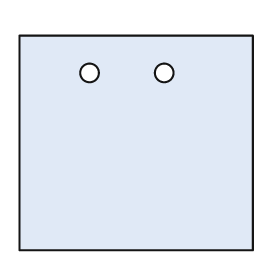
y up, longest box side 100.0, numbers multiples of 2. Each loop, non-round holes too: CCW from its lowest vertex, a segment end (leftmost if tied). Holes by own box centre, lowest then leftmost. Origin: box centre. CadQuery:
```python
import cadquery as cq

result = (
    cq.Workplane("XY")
    .moveTo(-50.0, -46.0)
    .lineTo(50.0, -46.0)
    .lineTo(50.0, 46.0)
    .lineTo(-50.0, 46.0)
    .close()
    .moveTo(-20.0, 30.0)
    .circle(4.0)
    .moveTo(12.0, 30.0)
    .circle(4.0)
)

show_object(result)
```